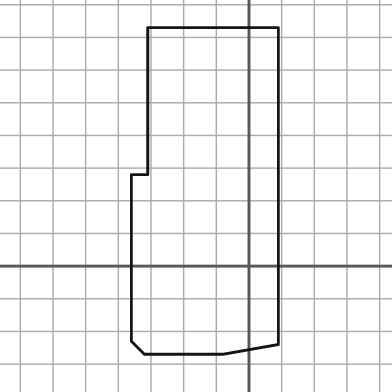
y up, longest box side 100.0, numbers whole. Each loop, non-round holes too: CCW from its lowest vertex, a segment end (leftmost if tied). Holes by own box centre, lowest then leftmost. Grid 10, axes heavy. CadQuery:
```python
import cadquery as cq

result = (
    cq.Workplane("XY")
    .moveTo(-32.0, -27.0)
    .lineTo(-8.0, -27.0)
    .lineTo(9.0, -24.0)
    .lineTo(9.0, 73.0)
    .lineTo(-31.0, 73.0)
    .lineTo(-31.0, 28.0)
    .lineTo(-36.0, 28.0)
    .lineTo(-36.0, -23.0)
    .close()
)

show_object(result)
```